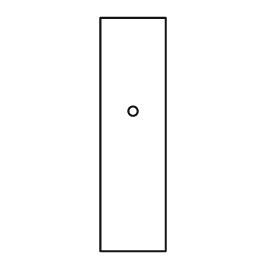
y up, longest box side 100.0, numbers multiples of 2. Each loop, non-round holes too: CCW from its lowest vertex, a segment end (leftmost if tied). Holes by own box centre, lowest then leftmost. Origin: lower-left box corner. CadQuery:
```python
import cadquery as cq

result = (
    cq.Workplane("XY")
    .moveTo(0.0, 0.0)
    .lineTo(28.0, 0.0)
    .lineTo(28.0, 100.0)
    .lineTo(0.0, 100.0)
    .close()
    .moveTo(14.0, 60.0)
    .circle(2.0)
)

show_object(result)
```